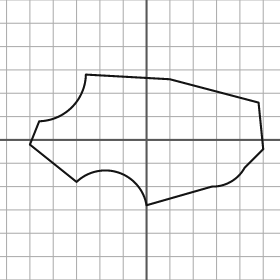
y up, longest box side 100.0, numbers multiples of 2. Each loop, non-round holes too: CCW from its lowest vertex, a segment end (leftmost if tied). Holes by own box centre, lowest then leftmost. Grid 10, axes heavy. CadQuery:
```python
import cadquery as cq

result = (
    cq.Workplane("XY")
    .moveTo(0.0, -28.0)
    .lineTo(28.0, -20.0)
    .threePointArc((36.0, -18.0), (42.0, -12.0))
    .lineTo(50.0, -4.0)
    .lineTo(48.0, 16.0)
    .lineTo(10.0, 26.0)
    .lineTo(-26.0, 28.0)
    .threePointArc((-32.0, 14.0), (-46.0, 8.0))
    .lineTo(-50.0, -2.0)
    .lineTo(-30.0, -18.0)
    .threePointArc((-12.0, -14.0), (0.0, -28.0))
    .close()
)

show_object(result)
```